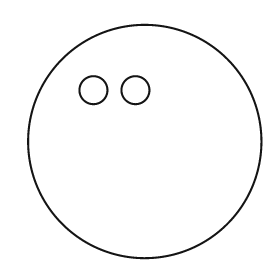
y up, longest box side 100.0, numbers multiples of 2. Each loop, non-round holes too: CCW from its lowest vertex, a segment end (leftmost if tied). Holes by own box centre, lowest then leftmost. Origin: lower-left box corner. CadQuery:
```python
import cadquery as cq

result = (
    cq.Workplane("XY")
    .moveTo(50.0, 50.0)
    .circle(50.0)
    .moveTo(28.0, 72.0)
    .circle(6.0)
    .moveTo(46.0, 72.0)
    .circle(6.0)
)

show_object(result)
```